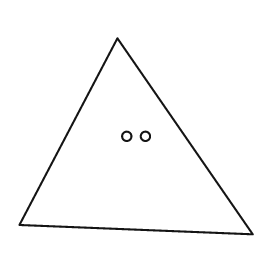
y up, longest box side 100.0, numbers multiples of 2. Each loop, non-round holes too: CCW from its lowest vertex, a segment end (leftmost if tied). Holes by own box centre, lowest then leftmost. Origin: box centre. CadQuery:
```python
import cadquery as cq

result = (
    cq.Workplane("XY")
    .moveTo(50.0, -42.0)
    .lineTo(-8.0, 42.0)
    .lineTo(-50.0, -38.0)
    .close()
    .moveTo(-4.0, 0.0)
    .circle(2.0)
    .moveTo(4.0, 0.0)
    .circle(2.0)
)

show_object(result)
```